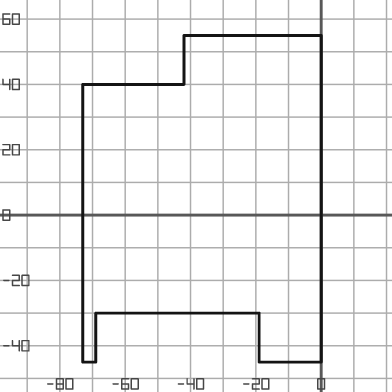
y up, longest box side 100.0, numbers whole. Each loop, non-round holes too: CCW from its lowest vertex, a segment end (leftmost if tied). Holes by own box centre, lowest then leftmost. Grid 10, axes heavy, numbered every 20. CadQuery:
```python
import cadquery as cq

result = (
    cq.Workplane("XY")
    .moveTo(-73.0, -45.0)
    .lineTo(-69.0, -45.0)
    .lineTo(-69.0, -30.0)
    .lineTo(-19.0, -30.0)
    .lineTo(-19.0, -45.0)
    .lineTo(0.0, -45.0)
    .lineTo(0.0, 55.0)
    .lineTo(-42.0, 55.0)
    .lineTo(-42.0, 40.0)
    .lineTo(-73.0, 40.0)
    .close()
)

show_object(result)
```